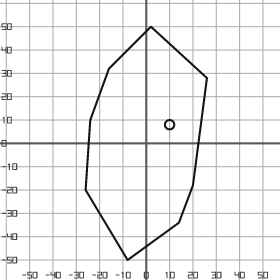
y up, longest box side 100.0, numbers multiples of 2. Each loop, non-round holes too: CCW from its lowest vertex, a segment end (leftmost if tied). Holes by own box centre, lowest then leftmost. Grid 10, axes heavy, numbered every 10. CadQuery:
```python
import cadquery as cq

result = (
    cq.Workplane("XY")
    .moveTo(-8.0, -50.0)
    .lineTo(14.0, -34.0)
    .lineTo(20.0, -18.0)
    .lineTo(26.0, 28.0)
    .lineTo(2.0, 50.0)
    .lineTo(-16.0, 32.0)
    .lineTo(-24.0, 10.0)
    .lineTo(-26.0, -20.0)
    .close()
    .moveTo(10.0, 8.0)
    .circle(2.0)
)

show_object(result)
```